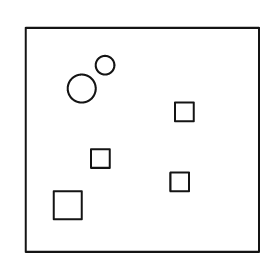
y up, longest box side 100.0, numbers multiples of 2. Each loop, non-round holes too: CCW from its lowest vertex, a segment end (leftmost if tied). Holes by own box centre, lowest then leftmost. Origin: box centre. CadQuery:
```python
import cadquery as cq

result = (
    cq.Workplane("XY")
    .moveTo(-50.0, -48.0)
    .lineTo(50.0, -48.0)
    .lineTo(50.0, 48.0)
    .lineTo(-50.0, 48.0)
    .close()
    .moveTo(-38.0, -34.0)
    .lineTo(-26.0, -34.0)
    .lineTo(-26.0, -22.0)
    .lineTo(-38.0, -22.0)
    .close()
    .moveTo(12.0, -22.0)
    .lineTo(20.0, -22.0)
    .lineTo(20.0, -14.0)
    .lineTo(12.0, -14.0)
    .close()
    .moveTo(-22.0, -12.0)
    .lineTo(-14.0, -12.0)
    .lineTo(-14.0, -4.0)
    .lineTo(-22.0, -4.0)
    .close()
    .moveTo(14.0, 8.0)
    .lineTo(22.0, 8.0)
    .lineTo(22.0, 16.0)
    .lineTo(14.0, 16.0)
    .close()
    .moveTo(-26.0, 22.0)
    .circle(6.0)
    .moveTo(-16.0, 32.0)
    .circle(4.0)
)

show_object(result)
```